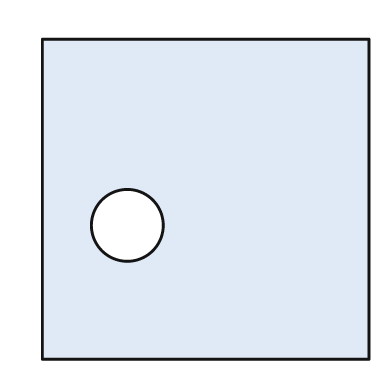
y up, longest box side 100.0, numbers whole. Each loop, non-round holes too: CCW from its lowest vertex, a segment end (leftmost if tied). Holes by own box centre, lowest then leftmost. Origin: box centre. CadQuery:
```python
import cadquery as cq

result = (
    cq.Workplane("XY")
    .moveTo(-50.0, -49.0)
    .lineTo(50.0, -49.0)
    .lineTo(50.0, 49.0)
    .lineTo(-50.0, 49.0)
    .close()
    .moveTo(-24.0, -8.0)
    .circle(11.0)
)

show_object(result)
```